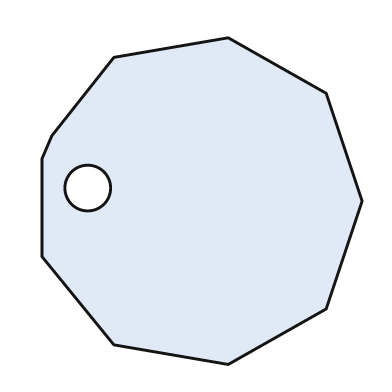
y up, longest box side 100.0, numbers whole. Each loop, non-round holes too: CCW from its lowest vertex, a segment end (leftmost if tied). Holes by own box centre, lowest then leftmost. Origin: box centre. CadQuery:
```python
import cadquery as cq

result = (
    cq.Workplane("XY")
    .moveTo(8.0, -50.0)
    .lineTo(38.0, -33.0)
    .lineTo(49.0, 0.0)
    .lineTo(38.0, 33.0)
    .lineTo(8.0, 50.0)
    .lineTo(-27.0, 44.0)
    .lineTo(-46.0, 20.0)
    .lineTo(-49.0, 13.0)
    .lineTo(-49.0, -17.0)
    .lineTo(-27.0, -44.0)
    .close()
    .moveTo(-35.0, 4.0)
    .circle(7.0)
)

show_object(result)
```